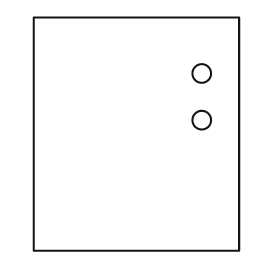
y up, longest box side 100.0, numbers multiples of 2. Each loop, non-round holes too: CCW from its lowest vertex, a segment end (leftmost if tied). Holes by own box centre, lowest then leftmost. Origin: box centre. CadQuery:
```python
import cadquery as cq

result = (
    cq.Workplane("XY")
    .moveTo(-44.0, -50.0)
    .lineTo(44.0, -50.0)
    .lineTo(44.0, 50.0)
    .lineTo(-44.0, 50.0)
    .close()
    .moveTo(28.0, 6.0)
    .circle(4.0)
    .moveTo(28.0, 26.0)
    .circle(4.0)
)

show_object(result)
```